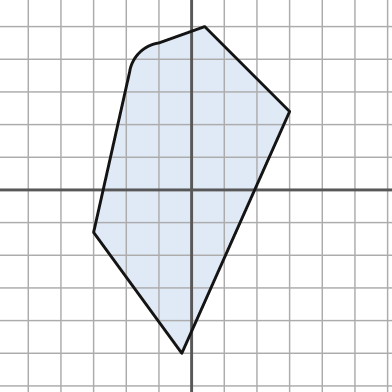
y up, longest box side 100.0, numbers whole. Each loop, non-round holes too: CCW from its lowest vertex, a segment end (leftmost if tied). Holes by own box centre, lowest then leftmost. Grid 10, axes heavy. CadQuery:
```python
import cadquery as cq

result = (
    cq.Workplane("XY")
    .moveTo(-3.0, -50.0)
    .lineTo(30.0, 24.0)
    .lineTo(4.0, 50.0)
    .lineTo(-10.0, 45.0)
    .threePointArc((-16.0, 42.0), (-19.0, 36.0))
    .lineTo(-30.0, -13.0)
    .close()
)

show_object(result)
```